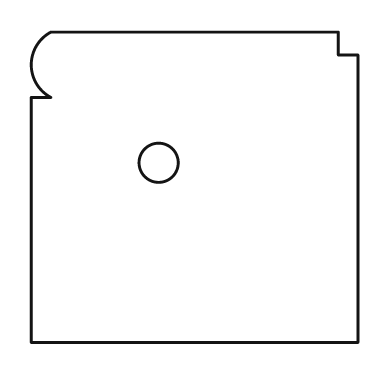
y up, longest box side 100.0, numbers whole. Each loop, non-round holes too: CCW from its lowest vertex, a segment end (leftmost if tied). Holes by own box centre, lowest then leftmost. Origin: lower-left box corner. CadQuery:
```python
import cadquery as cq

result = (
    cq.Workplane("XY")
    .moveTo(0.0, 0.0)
    .lineTo(100.0, 0.0)
    .lineTo(100.0, 88.0)
    .lineTo(94.0, 88.0)
    .lineTo(94.0, 95.0)
    .lineTo(6.0, 95.0)
    .threePointArc((0.0, 85.0), (6.0, 75.0))
    .lineTo(0.0, 75.0)
    .close()
    .moveTo(39.0, 55.0)
    .circle(6.0)
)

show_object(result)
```